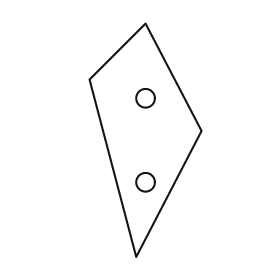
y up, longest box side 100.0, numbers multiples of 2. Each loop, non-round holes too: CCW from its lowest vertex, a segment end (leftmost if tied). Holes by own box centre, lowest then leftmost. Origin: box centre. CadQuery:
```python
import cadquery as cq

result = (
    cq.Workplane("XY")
    .moveTo(-4.0, -50.0)
    .lineTo(24.0, 4.0)
    .lineTo(0.0, 50.0)
    .lineTo(-24.0, 26.0)
    .close()
    .moveTo(0.0, -18.0)
    .circle(4.0)
    .moveTo(0.0, 18.0)
    .circle(4.0)
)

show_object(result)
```